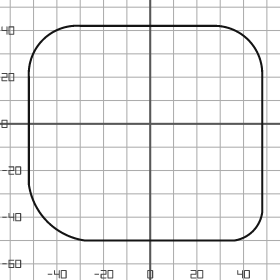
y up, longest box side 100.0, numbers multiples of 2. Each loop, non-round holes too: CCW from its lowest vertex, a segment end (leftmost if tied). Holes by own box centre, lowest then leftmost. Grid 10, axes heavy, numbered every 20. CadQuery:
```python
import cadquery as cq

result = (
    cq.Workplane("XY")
    .moveTo(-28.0, -50.0)
    .lineTo(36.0, -50.0)
    .threePointArc((44.0, -46.0), (48.0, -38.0))
    .lineTo(48.0, 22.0)
    .threePointArc((42.0, 36.0), (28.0, 42.0))
    .lineTo(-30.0, 42.0)
    .threePointArc((-46.0, 36.0), (-52.0, 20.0))
    .lineTo(-52.0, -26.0)
    .threePointArc((-44.0, -42.0), (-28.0, -50.0))
    .close()
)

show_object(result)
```